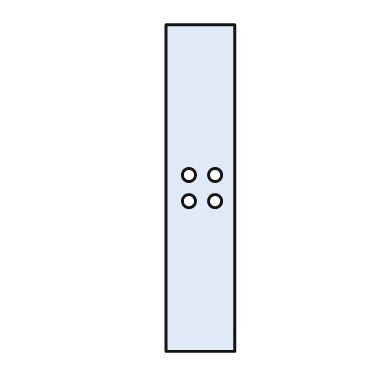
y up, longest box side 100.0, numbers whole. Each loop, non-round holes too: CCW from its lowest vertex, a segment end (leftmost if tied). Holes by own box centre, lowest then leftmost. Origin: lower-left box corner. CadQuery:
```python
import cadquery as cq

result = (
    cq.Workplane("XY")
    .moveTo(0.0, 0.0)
    .lineTo(21.0, 0.0)
    .lineTo(21.0, 100.0)
    .lineTo(0.0, 100.0)
    .close()
    .moveTo(7.0, 46.0)
    .circle(2.0)
    .moveTo(15.0, 46.0)
    .circle(2.0)
    .moveTo(7.0, 54.0)
    .circle(2.0)
    .moveTo(15.0, 54.0)
    .circle(2.0)
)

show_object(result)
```